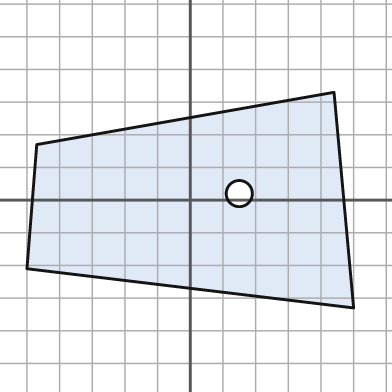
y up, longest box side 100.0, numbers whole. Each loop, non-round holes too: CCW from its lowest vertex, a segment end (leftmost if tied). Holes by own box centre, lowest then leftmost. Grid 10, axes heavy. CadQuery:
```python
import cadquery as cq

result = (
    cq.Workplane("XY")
    .moveTo(50.0, -33.0)
    .lineTo(44.0, 33.0)
    .lineTo(-47.0, 17.0)
    .lineTo(-50.0, -21.0)
    .close()
    .moveTo(15.0, 2.0)
    .circle(4.0)
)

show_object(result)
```